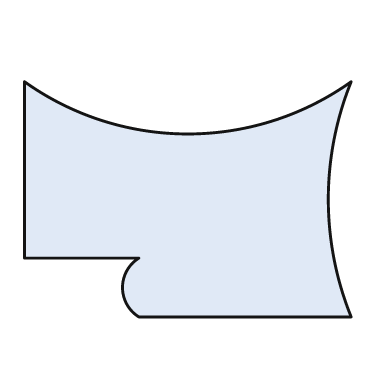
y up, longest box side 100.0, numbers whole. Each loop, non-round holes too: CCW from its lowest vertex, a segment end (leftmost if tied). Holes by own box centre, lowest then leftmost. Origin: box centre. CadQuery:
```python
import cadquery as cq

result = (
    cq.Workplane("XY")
    .moveTo(-15.0, -36.0)
    .lineTo(50.0, -36.0)
    .threePointArc((43.0, 0.0), (50.0, 36.0))
    .threePointArc((0.0, 20.0), (-50.0, 36.0))
    .lineTo(-50.0, -18.0)
    .lineTo(-15.0, -18.0)
    .threePointArc((-20.0, -27.0), (-15.0, -36.0))
    .close()
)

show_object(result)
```